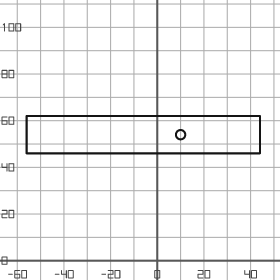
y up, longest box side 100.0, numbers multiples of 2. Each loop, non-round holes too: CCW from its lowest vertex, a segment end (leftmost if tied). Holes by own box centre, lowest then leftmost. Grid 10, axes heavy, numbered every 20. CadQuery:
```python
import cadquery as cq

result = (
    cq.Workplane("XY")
    .moveTo(-56.0, 46.0)
    .lineTo(44.0, 46.0)
    .lineTo(44.0, 62.0)
    .lineTo(-56.0, 62.0)
    .close()
    .moveTo(10.0, 54.0)
    .circle(2.0)
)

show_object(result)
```